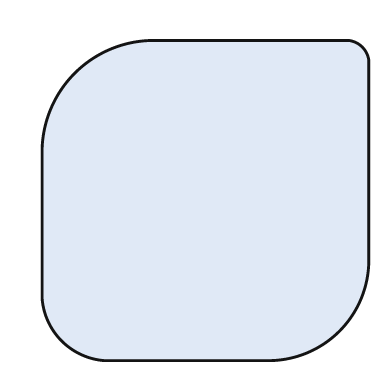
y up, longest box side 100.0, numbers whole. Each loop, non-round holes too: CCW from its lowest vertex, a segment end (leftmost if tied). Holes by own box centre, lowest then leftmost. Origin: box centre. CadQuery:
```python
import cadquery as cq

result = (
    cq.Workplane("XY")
    .moveTo(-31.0, -49.0)
    .lineTo(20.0, -49.0)
    .threePointArc((41.0, -40.0), (50.0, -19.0))
    .lineTo(50.0, 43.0)
    .threePointArc((48.0, 47.0), (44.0, 49.0))
    .lineTo(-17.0, 49.0)
    .threePointArc((-40.0, 39.0), (-50.0, 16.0))
    .lineTo(-50.0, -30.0)
    .threePointArc((-44.0, -43.0), (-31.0, -49.0))
    .close()
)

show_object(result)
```